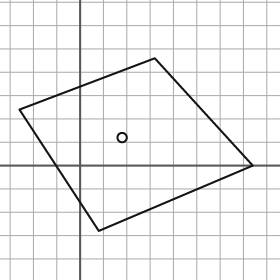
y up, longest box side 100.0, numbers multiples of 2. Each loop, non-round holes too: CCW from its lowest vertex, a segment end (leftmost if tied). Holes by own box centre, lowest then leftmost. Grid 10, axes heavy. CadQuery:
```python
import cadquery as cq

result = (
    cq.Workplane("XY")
    .moveTo(8.0, -28.0)
    .lineTo(74.0, 0.0)
    .lineTo(32.0, 46.0)
    .lineTo(-26.0, 24.0)
    .close()
    .moveTo(18.0, 12.0)
    .circle(2.0)
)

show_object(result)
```